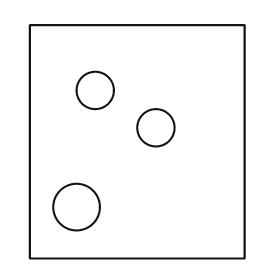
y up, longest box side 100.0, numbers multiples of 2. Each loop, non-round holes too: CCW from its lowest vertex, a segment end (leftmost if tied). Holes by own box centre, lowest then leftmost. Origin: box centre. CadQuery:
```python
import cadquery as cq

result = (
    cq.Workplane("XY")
    .moveTo(-46.0, -50.0)
    .lineTo(46.0, -50.0)
    .lineTo(46.0, 50.0)
    .lineTo(-46.0, 50.0)
    .close()
    .moveTo(-26.0, -28.0)
    .circle(10.0)
    .moveTo(8.0, 6.0)
    .circle(8.0)
    .moveTo(-18.0, 22.0)
    .circle(8.0)
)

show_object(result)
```